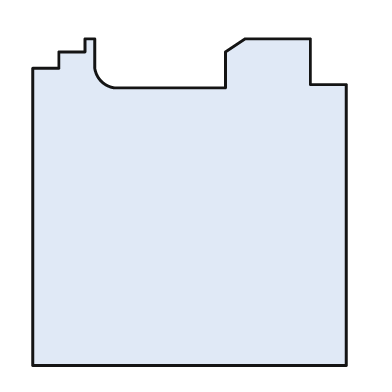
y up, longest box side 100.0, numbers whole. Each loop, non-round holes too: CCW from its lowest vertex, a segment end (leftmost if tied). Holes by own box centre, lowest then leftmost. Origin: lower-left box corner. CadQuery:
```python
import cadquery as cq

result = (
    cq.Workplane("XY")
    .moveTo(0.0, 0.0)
    .lineTo(96.0, 0.0)
    .lineTo(96.0, 86.0)
    .lineTo(85.0, 86.0)
    .lineTo(85.0, 100.0)
    .lineTo(65.0, 100.0)
    .lineTo(59.0, 96.0)
    .lineTo(59.0, 85.0)
    .lineTo(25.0, 85.0)
    .threePointArc((21.0, 87.0), (19.0, 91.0))
    .lineTo(19.0, 100.0)
    .lineTo(16.0, 100.0)
    .lineTo(16.0, 96.0)
    .lineTo(8.0, 96.0)
    .lineTo(8.0, 91.0)
    .lineTo(0.0, 91.0)
    .close()
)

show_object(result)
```